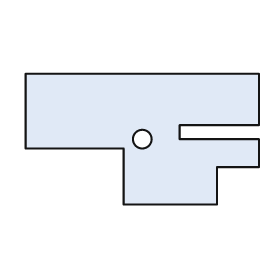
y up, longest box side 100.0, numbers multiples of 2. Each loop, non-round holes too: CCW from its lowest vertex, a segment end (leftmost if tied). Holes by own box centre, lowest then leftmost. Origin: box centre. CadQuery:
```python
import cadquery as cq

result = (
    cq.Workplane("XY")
    .moveTo(-8.0, -28.0)
    .lineTo(32.0, -28.0)
    .lineTo(32.0, -12.0)
    .lineTo(50.0, -12.0)
    .lineTo(50.0, 0.0)
    .lineTo(16.0, 0.0)
    .lineTo(16.0, 6.0)
    .lineTo(50.0, 6.0)
    .lineTo(50.0, 28.0)
    .lineTo(-50.0, 28.0)
    .lineTo(-50.0, -4.0)
    .lineTo(-8.0, -4.0)
    .close()
    .moveTo(0.0, 0.0)
    .circle(4.0)
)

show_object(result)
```